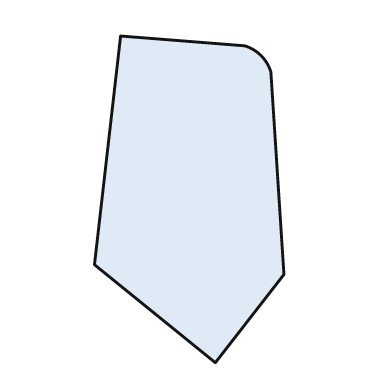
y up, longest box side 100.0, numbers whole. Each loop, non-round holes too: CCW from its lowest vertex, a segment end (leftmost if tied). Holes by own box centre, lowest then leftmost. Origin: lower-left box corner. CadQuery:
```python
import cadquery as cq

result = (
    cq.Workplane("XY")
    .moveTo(37.0, 0.0)
    .lineTo(58.0, 27.0)
    .lineTo(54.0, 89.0)
    .threePointArc((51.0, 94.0), (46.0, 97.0))
    .lineTo(8.0, 100.0)
    .lineTo(0.0, 30.0)
    .close()
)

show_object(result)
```